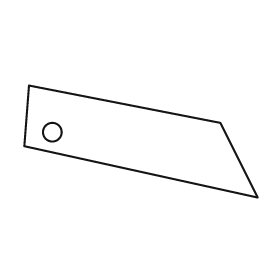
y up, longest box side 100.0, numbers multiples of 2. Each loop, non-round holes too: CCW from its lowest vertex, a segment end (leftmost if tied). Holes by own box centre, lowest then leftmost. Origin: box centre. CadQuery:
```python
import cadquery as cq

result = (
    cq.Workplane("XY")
    .moveTo(50.0, -24.0)
    .lineTo(34.0, 8.0)
    .lineTo(-48.0, 24.0)
    .lineTo(-50.0, -2.0)
    .close()
    .moveTo(-38.0, 4.0)
    .circle(4.0)
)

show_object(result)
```